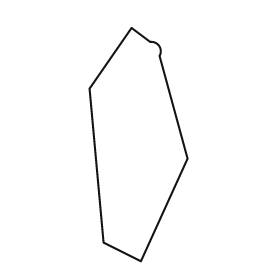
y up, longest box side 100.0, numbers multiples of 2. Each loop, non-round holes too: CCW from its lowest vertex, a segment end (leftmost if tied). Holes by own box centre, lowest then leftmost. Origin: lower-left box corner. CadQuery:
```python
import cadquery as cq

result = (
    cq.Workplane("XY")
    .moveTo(22.0, 0.0)
    .lineTo(42.0, 44.0)
    .lineTo(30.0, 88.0)
    .threePointArc((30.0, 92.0), (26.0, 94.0))
    .lineTo(18.0, 100.0)
    .lineTo(0.0, 74.0)
    .lineTo(6.0, 8.0)
    .close()
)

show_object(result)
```